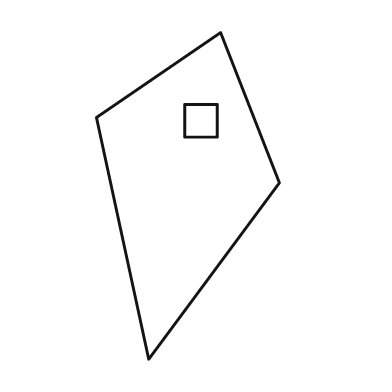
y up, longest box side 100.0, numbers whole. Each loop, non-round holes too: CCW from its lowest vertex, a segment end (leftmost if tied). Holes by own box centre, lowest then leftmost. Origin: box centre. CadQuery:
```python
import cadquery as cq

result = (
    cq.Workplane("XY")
    .moveTo(-12.0, -50.0)
    .lineTo(28.0, 4.0)
    .lineTo(10.0, 50.0)
    .lineTo(-28.0, 24.0)
    .close()
    .moveTo(-1.0, 18.0)
    .lineTo(9.0, 18.0)
    .lineTo(9.0, 28.0)
    .lineTo(-1.0, 28.0)
    .close()
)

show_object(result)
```